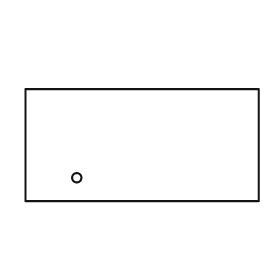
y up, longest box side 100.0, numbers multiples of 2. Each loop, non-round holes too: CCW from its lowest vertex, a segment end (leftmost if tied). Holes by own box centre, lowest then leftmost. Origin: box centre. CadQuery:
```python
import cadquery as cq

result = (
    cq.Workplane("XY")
    .moveTo(-50.0, -24.0)
    .lineTo(50.0, -24.0)
    .lineTo(50.0, 24.0)
    .lineTo(-50.0, 24.0)
    .close()
    .moveTo(-28.0, -14.0)
    .circle(2.0)
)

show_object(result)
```